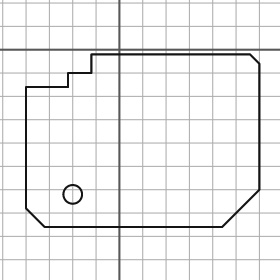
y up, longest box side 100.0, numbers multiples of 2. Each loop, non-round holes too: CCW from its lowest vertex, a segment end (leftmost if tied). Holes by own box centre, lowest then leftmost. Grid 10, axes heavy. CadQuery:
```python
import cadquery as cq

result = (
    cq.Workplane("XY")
    .moveTo(-32.0, -76.0)
    .lineTo(44.0, -76.0)
    .lineTo(60.0, -60.0)
    .lineTo(60.0, -6.0)
    .lineTo(56.0, -2.0)
    .lineTo(-12.0, -2.0)
    .lineTo(-12.0, -10.0)
    .lineTo(-22.0, -10.0)
    .lineTo(-22.0, -16.0)
    .lineTo(-40.0, -16.0)
    .lineTo(-40.0, -68.0)
    .close()
    .moveTo(-20.0, -62.0)
    .circle(4.0)
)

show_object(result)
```